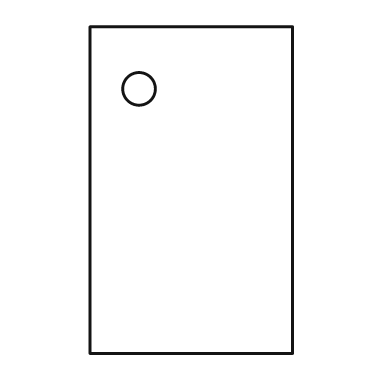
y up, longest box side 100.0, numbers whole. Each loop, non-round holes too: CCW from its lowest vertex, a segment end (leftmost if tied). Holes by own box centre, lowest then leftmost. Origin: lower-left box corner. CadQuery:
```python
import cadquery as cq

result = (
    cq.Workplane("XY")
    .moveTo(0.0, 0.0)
    .lineTo(62.0, 0.0)
    .lineTo(62.0, 100.0)
    .lineTo(0.0, 100.0)
    .close()
    .moveTo(15.0, 81.0)
    .circle(5.0)
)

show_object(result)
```